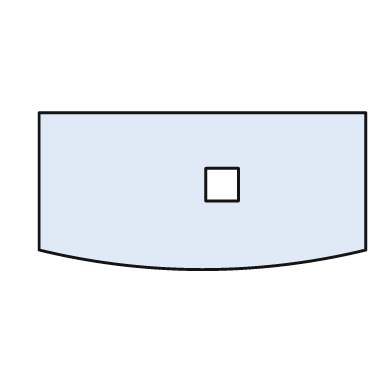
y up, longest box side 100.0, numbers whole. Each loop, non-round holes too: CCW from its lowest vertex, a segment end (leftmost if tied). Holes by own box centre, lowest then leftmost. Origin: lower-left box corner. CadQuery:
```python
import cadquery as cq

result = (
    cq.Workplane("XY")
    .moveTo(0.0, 6.0)
    .threePointArc((50.0, 0.0), (100.0, 6.0))
    .lineTo(100.0, 48.0)
    .lineTo(0.0, 48.0)
    .close()
    .moveTo(51.0, 21.0)
    .lineTo(61.0, 21.0)
    .lineTo(61.0, 31.0)
    .lineTo(51.0, 31.0)
    .close()
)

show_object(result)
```